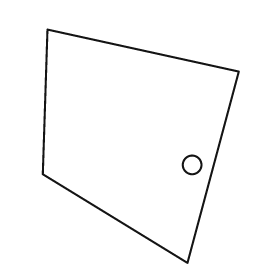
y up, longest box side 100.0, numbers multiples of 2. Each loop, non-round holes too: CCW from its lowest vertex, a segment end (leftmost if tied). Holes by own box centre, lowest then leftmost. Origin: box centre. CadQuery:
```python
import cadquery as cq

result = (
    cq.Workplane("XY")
    .moveTo(20.0, -50.0)
    .lineTo(42.0, 32.0)
    .lineTo(-40.0, 50.0)
    .lineTo(-42.0, -12.0)
    .close()
    .moveTo(22.0, -8.0)
    .circle(4.0)
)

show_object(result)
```